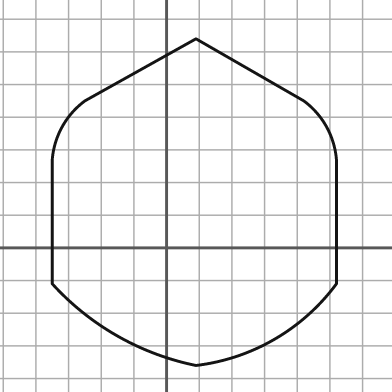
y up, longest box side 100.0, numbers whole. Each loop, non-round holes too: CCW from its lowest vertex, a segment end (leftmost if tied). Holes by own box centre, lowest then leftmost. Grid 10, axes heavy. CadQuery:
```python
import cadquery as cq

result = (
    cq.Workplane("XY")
    .moveTo(9.0, -36.0)
    .threePointArc((33.0, -28.0), (52.0, -11.0))
    .lineTo(52.0, 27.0)
    .threePointArc((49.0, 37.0), (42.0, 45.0))
    .lineTo(9.0, 64.0)
    .lineTo(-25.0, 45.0)
    .threePointArc((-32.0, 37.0), (-35.0, 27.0))
    .lineTo(-35.0, -11.0)
    .threePointArc((-15.0, -27.0), (9.0, -36.0))
    .close()
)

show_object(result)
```